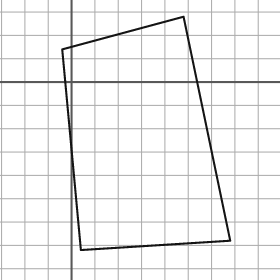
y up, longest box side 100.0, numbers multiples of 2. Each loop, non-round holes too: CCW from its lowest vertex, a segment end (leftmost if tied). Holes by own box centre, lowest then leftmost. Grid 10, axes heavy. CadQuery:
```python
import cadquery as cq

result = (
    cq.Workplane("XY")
    .moveTo(4.0, -72.0)
    .lineTo(68.0, -68.0)
    .lineTo(48.0, 28.0)
    .lineTo(-4.0, 14.0)
    .close()
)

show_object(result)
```